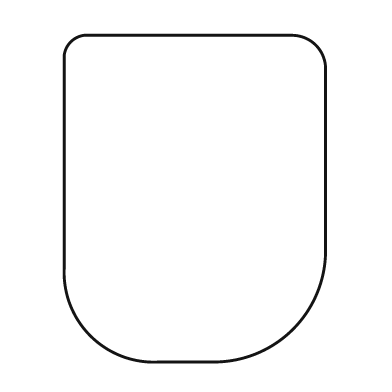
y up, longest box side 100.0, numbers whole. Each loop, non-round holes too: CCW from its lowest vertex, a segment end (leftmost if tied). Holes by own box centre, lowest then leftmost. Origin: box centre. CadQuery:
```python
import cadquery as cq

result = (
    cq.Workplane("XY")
    .moveTo(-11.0, -50.0)
    .lineTo(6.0, -50.0)
    .threePointArc((30.0, -40.0), (40.0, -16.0))
    .lineTo(40.0, 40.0)
    .threePointArc((37.0, 47.0), (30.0, 50.0))
    .lineTo(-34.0, 50.0)
    .threePointArc((-38.0, 48.0), (-40.0, 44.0))
    .lineTo(-40.0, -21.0)
    .threePointArc((-32.0, -42.0), (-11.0, -50.0))
    .close()
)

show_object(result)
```